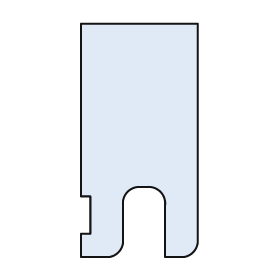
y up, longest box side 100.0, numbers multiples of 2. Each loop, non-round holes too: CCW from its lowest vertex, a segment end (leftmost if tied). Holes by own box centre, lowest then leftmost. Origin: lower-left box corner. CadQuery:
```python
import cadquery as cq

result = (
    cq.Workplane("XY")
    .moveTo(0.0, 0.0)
    .lineTo(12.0, 0.0)
    .threePointArc((16.0, 2.0), (18.0, 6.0))
    .lineTo(18.0, 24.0)
    .threePointArc((20.0, 28.0), (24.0, 30.0))
    .lineTo(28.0, 30.0)
    .threePointArc((34.0, 28.0), (36.0, 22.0))
    .lineTo(36.0, 0.0)
    .lineTo(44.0, 0.0)
    .threePointArc((48.0, 2.0), (50.0, 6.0))
    .lineTo(50.0, 100.0)
    .lineTo(0.0, 100.0)
    .lineTo(0.0, 26.0)
    .lineTo(4.0, 26.0)
    .lineTo(4.0, 10.0)
    .lineTo(0.0, 10.0)
    .close()
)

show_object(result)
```